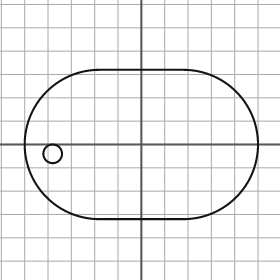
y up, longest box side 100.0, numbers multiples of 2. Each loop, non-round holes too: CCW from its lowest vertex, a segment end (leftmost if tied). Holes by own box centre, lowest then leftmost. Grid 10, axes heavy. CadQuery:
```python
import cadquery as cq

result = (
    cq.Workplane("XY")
    .moveTo(-18.0, -32.0)
    .lineTo(18.0, -32.0)
    .threePointArc((50.0, 0.0), (18.0, 32.0))
    .lineTo(-18.0, 32.0)
    .threePointArc((-50.0, 0.0), (-18.0, -32.0))
    .close()
    .moveTo(-38.0, -4.0)
    .circle(4.0)
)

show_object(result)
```